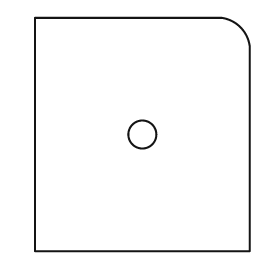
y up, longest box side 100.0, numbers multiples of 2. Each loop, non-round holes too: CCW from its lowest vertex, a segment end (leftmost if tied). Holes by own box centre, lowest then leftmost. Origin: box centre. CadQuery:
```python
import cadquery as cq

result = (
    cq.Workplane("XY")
    .moveTo(-46.0, -50.0)
    .lineTo(46.0, -50.0)
    .lineTo(46.0, 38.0)
    .threePointArc((42.0, 46.0), (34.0, 50.0))
    .lineTo(-46.0, 50.0)
    .close()
    .moveTo(0.0, 0.0)
    .circle(6.0)
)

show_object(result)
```